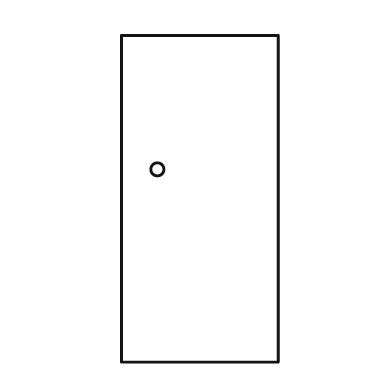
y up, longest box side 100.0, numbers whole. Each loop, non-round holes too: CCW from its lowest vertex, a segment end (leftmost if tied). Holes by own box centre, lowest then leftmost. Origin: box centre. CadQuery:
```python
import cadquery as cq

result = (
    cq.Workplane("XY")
    .moveTo(-24.0, -50.0)
    .lineTo(24.0, -50.0)
    .lineTo(24.0, 50.0)
    .lineTo(-24.0, 50.0)
    .close()
    .moveTo(-13.0, 9.0)
    .circle(2.0)
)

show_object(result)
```